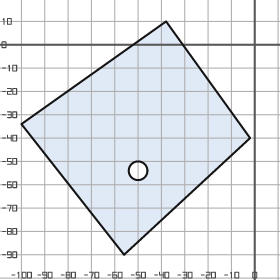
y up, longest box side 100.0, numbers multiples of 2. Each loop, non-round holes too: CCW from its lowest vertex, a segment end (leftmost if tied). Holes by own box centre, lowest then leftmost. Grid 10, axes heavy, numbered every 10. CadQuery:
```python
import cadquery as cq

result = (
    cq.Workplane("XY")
    .moveTo(-56.0, -90.0)
    .lineTo(-2.0, -40.0)
    .lineTo(-38.0, 10.0)
    .lineTo(-100.0, -34.0)
    .close()
    .moveTo(-50.0, -54.0)
    .circle(4.0)
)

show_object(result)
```